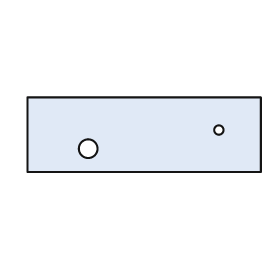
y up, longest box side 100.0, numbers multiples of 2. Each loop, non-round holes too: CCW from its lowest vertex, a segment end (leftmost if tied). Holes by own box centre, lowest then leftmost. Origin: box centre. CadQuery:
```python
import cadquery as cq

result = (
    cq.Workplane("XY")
    .moveTo(-50.0, -16.0)
    .lineTo(50.0, -16.0)
    .lineTo(50.0, 16.0)
    .lineTo(-50.0, 16.0)
    .close()
    .moveTo(-24.0, -6.0)
    .circle(4.0)
    .moveTo(32.0, 2.0)
    .circle(2.0)
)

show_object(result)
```